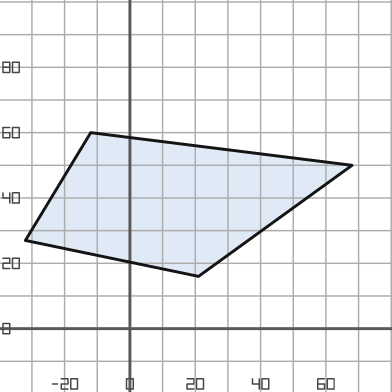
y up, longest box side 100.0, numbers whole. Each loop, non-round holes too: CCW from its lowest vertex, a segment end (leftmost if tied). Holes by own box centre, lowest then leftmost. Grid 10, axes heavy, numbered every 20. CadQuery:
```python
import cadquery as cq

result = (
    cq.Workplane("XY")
    .moveTo(21.0, 16.0)
    .lineTo(68.0, 50.0)
    .lineTo(-12.0, 60.0)
    .lineTo(-32.0, 27.0)
    .close()
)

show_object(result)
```